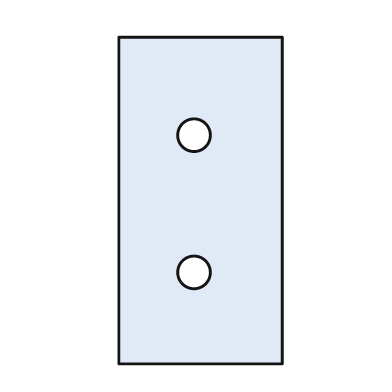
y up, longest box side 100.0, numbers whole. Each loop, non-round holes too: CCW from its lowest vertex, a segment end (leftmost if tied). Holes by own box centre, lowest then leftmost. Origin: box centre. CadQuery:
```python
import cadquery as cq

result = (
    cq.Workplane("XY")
    .moveTo(-25.0, -50.0)
    .lineTo(25.0, -50.0)
    .lineTo(25.0, 50.0)
    .lineTo(-25.0, 50.0)
    .close()
    .moveTo(-2.0, -22.0)
    .circle(5.0)
    .moveTo(-2.0, 20.0)
    .circle(5.0)
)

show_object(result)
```